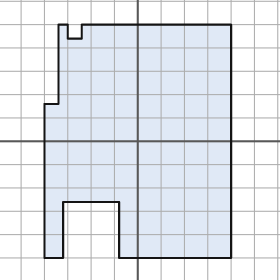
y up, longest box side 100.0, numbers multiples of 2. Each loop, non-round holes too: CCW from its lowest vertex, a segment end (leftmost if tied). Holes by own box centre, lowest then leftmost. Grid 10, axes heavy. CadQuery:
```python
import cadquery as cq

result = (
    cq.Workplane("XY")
    .moveTo(-40.0, -50.0)
    .lineTo(-32.0, -50.0)
    .lineTo(-32.0, -26.0)
    .lineTo(-8.0, -26.0)
    .lineTo(-8.0, -50.0)
    .lineTo(40.0, -50.0)
    .lineTo(40.0, 50.0)
    .lineTo(-24.0, 50.0)
    .lineTo(-24.0, 44.0)
    .lineTo(-30.0, 44.0)
    .lineTo(-30.0, 50.0)
    .lineTo(-34.0, 50.0)
    .lineTo(-34.0, 16.0)
    .lineTo(-40.0, 16.0)
    .close()
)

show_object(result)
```